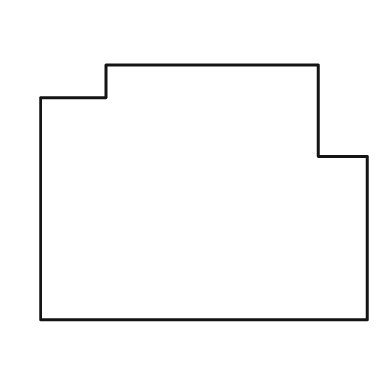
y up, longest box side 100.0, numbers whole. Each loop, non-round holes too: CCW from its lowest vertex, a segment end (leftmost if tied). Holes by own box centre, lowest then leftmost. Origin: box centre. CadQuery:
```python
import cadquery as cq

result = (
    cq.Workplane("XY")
    .moveTo(-50.0, -39.0)
    .lineTo(50.0, -39.0)
    .lineTo(50.0, 11.0)
    .lineTo(35.0, 11.0)
    .lineTo(35.0, 39.0)
    .lineTo(-30.0, 39.0)
    .lineTo(-30.0, 29.0)
    .lineTo(-50.0, 29.0)
    .close()
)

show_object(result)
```